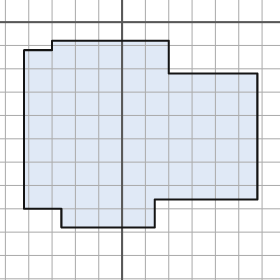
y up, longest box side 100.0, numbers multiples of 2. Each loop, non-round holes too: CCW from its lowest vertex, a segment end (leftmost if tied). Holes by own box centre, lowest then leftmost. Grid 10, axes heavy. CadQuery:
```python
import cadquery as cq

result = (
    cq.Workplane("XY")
    .moveTo(-26.0, -88.0)
    .lineTo(14.0, -88.0)
    .lineTo(14.0, -76.0)
    .lineTo(58.0, -76.0)
    .lineTo(58.0, -22.0)
    .lineTo(20.0, -22.0)
    .lineTo(20.0, -8.0)
    .lineTo(-30.0, -8.0)
    .lineTo(-30.0, -12.0)
    .lineTo(-42.0, -12.0)
    .lineTo(-42.0, -80.0)
    .lineTo(-26.0, -80.0)
    .close()
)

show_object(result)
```